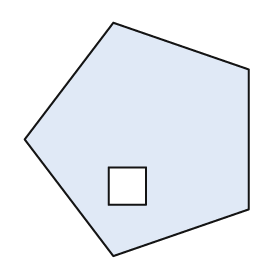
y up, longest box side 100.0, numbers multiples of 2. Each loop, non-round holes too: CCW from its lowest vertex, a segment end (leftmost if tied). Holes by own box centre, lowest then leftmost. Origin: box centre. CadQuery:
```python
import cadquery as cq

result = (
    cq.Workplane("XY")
    .moveTo(-10.0, -50.0)
    .lineTo(48.0, -30.0)
    .lineTo(48.0, 30.0)
    .lineTo(-10.0, 50.0)
    .lineTo(-48.0, 0.0)
    .close()
    .moveTo(-12.0, -28.0)
    .lineTo(4.0, -28.0)
    .lineTo(4.0, -12.0)
    .lineTo(-12.0, -12.0)
    .close()
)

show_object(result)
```